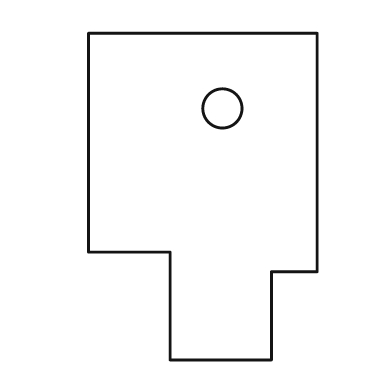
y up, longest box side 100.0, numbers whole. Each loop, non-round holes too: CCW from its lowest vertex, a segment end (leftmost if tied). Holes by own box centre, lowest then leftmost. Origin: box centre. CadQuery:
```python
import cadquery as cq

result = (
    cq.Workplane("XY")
    .moveTo(-10.0, -50.0)
    .lineTo(21.0, -50.0)
    .lineTo(21.0, -23.0)
    .lineTo(35.0, -23.0)
    .lineTo(35.0, 50.0)
    .lineTo(-35.0, 50.0)
    .lineTo(-35.0, -17.0)
    .lineTo(-10.0, -17.0)
    .close()
    .moveTo(6.0, 27.0)
    .circle(6.0)
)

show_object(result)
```